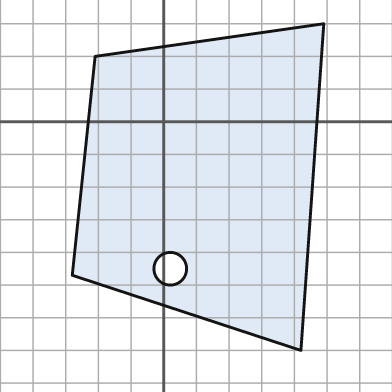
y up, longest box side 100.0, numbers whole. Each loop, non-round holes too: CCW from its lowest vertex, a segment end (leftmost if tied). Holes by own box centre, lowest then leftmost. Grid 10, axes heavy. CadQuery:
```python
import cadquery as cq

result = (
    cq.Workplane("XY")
    .moveTo(42.0, -70.0)
    .lineTo(49.0, 30.0)
    .lineTo(-21.0, 20.0)
    .lineTo(-28.0, -47.0)
    .close()
    .moveTo(2.0, -45.0)
    .circle(5.0)
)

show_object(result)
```